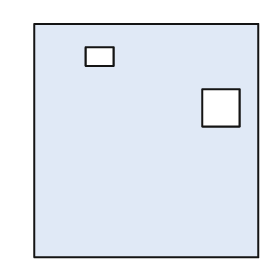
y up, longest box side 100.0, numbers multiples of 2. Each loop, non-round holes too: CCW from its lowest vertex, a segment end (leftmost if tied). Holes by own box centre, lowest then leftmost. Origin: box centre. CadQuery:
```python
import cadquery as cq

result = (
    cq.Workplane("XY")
    .moveTo(-48.0, -50.0)
    .lineTo(48.0, -50.0)
    .lineTo(48.0, 50.0)
    .lineTo(-48.0, 50.0)
    .close()
    .moveTo(24.0, 6.0)
    .lineTo(40.0, 6.0)
    .lineTo(40.0, 22.0)
    .lineTo(24.0, 22.0)
    .close()
    .moveTo(-26.0, 32.0)
    .lineTo(-14.0, 32.0)
    .lineTo(-14.0, 40.0)
    .lineTo(-26.0, 40.0)
    .close()
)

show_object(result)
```